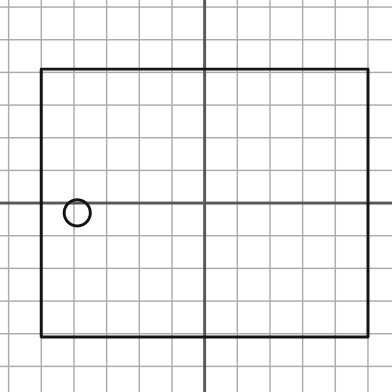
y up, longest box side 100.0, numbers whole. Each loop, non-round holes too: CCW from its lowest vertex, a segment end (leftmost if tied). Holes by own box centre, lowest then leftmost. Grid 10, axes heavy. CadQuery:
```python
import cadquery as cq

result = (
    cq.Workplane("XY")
    .moveTo(-50.0, -41.0)
    .lineTo(50.0, -41.0)
    .lineTo(50.0, 41.0)
    .lineTo(-50.0, 41.0)
    .close()
    .moveTo(-39.0, -3.0)
    .circle(4.0)
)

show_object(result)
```